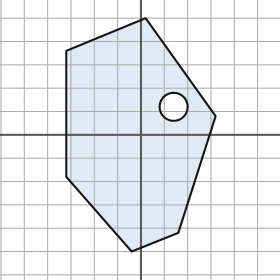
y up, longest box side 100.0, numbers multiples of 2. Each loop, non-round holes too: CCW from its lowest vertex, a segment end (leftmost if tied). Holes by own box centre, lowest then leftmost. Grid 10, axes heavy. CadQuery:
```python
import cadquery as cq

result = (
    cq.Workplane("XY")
    .moveTo(-4.0, -50.0)
    .lineTo(16.0, -42.0)
    .lineTo(32.0, 8.0)
    .lineTo(2.0, 50.0)
    .lineTo(-32.0, 36.0)
    .lineTo(-32.0, -18.0)
    .close()
    .moveTo(14.0, 12.0)
    .circle(6.0)
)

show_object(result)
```